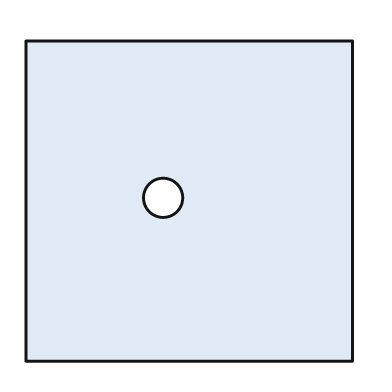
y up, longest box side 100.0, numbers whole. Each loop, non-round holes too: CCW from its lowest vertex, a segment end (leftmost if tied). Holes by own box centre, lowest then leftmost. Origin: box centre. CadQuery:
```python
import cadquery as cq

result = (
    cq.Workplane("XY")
    .moveTo(-50.0, -49.0)
    .lineTo(50.0, -49.0)
    .lineTo(50.0, 49.0)
    .lineTo(-50.0, 49.0)
    .close()
    .moveTo(-8.0, 1.0)
    .circle(6.0)
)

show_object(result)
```